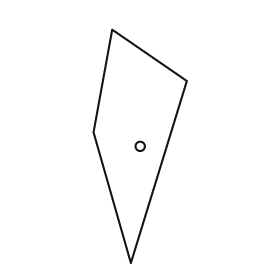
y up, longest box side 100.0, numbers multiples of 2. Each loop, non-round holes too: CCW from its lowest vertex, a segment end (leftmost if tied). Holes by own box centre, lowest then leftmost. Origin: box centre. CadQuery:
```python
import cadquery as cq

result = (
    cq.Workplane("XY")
    .moveTo(-4.0, -50.0)
    .lineTo(20.0, 28.0)
    .lineTo(-12.0, 50.0)
    .lineTo(-20.0, 6.0)
    .close()
    .moveTo(0.0, 0.0)
    .circle(2.0)
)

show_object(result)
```